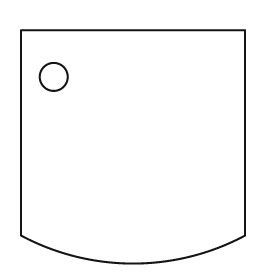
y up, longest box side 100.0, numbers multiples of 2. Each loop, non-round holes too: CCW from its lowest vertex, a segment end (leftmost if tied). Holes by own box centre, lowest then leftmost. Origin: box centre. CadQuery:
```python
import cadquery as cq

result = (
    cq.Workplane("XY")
    .moveTo(-48.0, -38.0)
    .threePointArc((0.0, -50.0), (48.0, -38.0))
    .lineTo(48.0, 50.0)
    .lineTo(-48.0, 50.0)
    .close()
    .moveTo(-34.0, 30.0)
    .circle(6.0)
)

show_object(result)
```